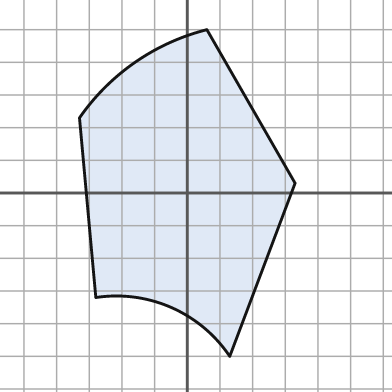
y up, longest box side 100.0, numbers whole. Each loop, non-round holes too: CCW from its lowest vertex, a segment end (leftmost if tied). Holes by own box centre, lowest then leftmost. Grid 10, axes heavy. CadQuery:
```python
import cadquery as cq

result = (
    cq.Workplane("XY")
    .moveTo(13.0, -50.0)
    .lineTo(33.0, 3.0)
    .lineTo(6.0, 50.0)
    .threePointArc((-16.0, 40.0), (-33.0, 23.0))
    .lineTo(-28.0, -32.0)
    .threePointArc((-5.0, -35.0), (13.0, -50.0))
    .close()
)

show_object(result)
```